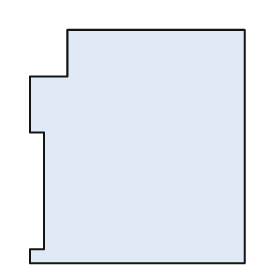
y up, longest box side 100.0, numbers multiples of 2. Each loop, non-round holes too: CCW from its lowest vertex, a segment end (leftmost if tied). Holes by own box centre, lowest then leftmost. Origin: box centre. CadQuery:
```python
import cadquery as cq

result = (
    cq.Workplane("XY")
    .moveTo(-46.0, -50.0)
    .lineTo(46.0, -50.0)
    .lineTo(46.0, 50.0)
    .lineTo(-30.0, 50.0)
    .lineTo(-30.0, 30.0)
    .lineTo(-46.0, 30.0)
    .lineTo(-46.0, 6.0)
    .lineTo(-40.0, 6.0)
    .lineTo(-40.0, -44.0)
    .lineTo(-46.0, -44.0)
    .close()
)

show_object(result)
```